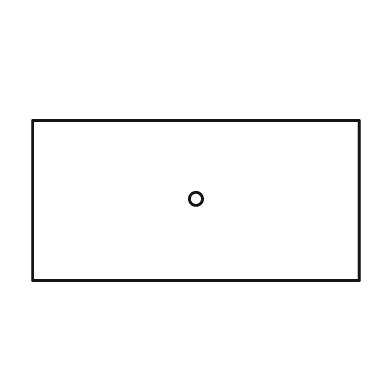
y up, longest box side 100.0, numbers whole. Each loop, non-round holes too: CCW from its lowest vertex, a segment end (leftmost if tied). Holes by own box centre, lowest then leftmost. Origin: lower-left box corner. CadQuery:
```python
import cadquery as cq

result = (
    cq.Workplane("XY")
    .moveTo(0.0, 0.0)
    .lineTo(100.0, 0.0)
    .lineTo(100.0, 49.0)
    .lineTo(0.0, 49.0)
    .close()
    .moveTo(50.0, 25.0)
    .circle(2.0)
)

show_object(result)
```